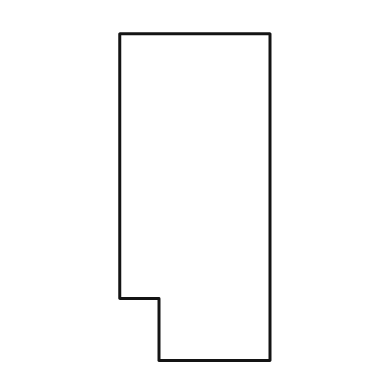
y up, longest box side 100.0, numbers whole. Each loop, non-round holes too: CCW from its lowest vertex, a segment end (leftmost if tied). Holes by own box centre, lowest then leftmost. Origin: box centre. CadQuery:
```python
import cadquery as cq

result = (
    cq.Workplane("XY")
    .moveTo(-11.0, -50.0)
    .lineTo(23.0, -50.0)
    .lineTo(23.0, 50.0)
    .lineTo(-23.0, 50.0)
    .lineTo(-23.0, -31.0)
    .lineTo(-11.0, -31.0)
    .close()
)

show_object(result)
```